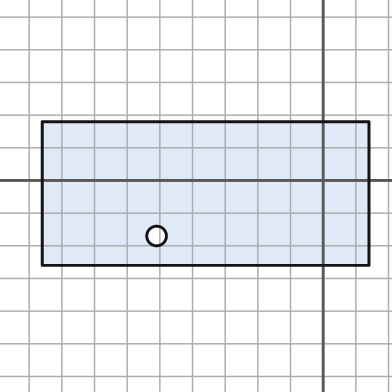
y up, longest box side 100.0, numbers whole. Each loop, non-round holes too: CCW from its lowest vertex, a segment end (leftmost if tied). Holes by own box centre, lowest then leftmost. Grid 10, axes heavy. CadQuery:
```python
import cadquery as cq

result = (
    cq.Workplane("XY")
    .moveTo(-86.0, -26.0)
    .lineTo(14.0, -26.0)
    .lineTo(14.0, 18.0)
    .lineTo(-86.0, 18.0)
    .close()
    .moveTo(-51.0, -17.0)
    .circle(3.0)
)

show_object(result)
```